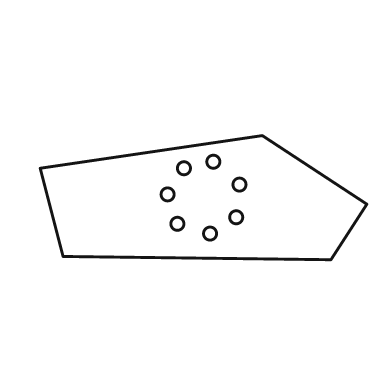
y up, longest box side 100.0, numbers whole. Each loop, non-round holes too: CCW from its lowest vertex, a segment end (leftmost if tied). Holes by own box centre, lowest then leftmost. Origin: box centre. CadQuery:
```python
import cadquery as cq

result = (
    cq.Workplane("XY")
    .moveTo(39.0, -19.0)
    .lineTo(50.0, -2.0)
    .lineTo(18.0, 19.0)
    .lineTo(-50.0, 9.0)
    .lineTo(-43.0, -18.0)
    .close()
    .moveTo(2.0, -11.0)
    .circle(2.0)
    .moveTo(-8.0, -8.0)
    .circle(2.0)
    .moveTo(10.0, -6.0)
    .circle(2.0)
    .moveTo(-11.0, 1.0)
    .circle(2.0)
    .moveTo(11.0, 4.0)
    .circle(2.0)
    .moveTo(-6.0, 9.0)
    .circle(2.0)
    .moveTo(3.0, 11.0)
    .circle(2.0)
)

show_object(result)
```